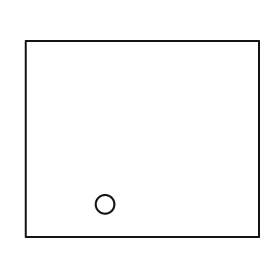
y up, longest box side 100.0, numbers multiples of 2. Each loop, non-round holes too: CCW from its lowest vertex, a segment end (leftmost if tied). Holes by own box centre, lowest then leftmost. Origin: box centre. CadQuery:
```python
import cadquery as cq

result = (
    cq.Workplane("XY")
    .moveTo(-50.0, -42.0)
    .lineTo(50.0, -42.0)
    .lineTo(50.0, 42.0)
    .lineTo(-50.0, 42.0)
    .close()
    .moveTo(-16.0, -28.0)
    .circle(4.0)
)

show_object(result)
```